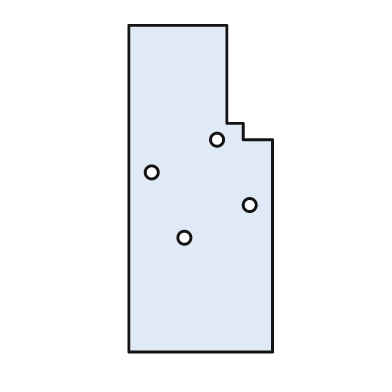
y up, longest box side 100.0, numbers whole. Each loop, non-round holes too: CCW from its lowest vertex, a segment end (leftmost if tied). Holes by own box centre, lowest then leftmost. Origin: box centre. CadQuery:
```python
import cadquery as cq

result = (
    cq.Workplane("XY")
    .moveTo(-22.0, -50.0)
    .lineTo(22.0, -50.0)
    .lineTo(22.0, 15.0)
    .lineTo(13.0, 15.0)
    .lineTo(13.0, 20.0)
    .lineTo(8.0, 20.0)
    .lineTo(8.0, 50.0)
    .lineTo(-22.0, 50.0)
    .close()
    .moveTo(-5.0, -15.0)
    .circle(2.0)
    .moveTo(15.0, -5.0)
    .circle(2.0)
    .moveTo(-15.0, 5.0)
    .circle(2.0)
    .moveTo(5.0, 15.0)
    .circle(2.0)
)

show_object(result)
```